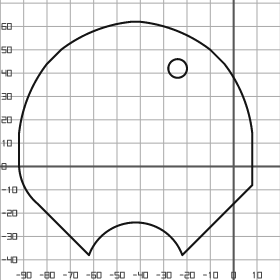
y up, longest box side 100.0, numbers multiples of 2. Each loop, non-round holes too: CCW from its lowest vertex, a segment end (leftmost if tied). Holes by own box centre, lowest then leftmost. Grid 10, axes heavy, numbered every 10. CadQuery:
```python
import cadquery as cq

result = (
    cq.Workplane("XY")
    .moveTo(-62.0, -38.0)
    .threePointArc((-42.0, -24.0), (-22.0, -38.0))
    .lineTo(8.0, -8.0)
    .lineTo(8.0, 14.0)
    .threePointArc((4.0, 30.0), (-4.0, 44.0))
    .lineTo(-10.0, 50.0)
    .threePointArc((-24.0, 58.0), (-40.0, 62.0))
    .lineTo(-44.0, 62.0)
    .threePointArc((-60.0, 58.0), (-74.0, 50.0))
    .lineTo(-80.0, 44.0)
    .threePointArc((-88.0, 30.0), (-92.0, 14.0))
    .lineTo(-92.0, 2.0)
    .threePointArc((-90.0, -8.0), (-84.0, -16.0))
    .close()
    .moveTo(-24.0, 42.0)
    .circle(4.0)
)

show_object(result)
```